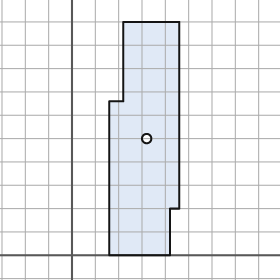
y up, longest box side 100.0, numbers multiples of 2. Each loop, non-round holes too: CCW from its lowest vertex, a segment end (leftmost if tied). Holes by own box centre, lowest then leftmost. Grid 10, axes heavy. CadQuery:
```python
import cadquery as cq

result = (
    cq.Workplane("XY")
    .moveTo(16.0, 0.0)
    .lineTo(42.0, 0.0)
    .lineTo(42.0, 20.0)
    .lineTo(46.0, 20.0)
    .lineTo(46.0, 100.0)
    .lineTo(22.0, 100.0)
    .lineTo(22.0, 66.0)
    .lineTo(16.0, 66.0)
    .close()
    .moveTo(32.0, 50.0)
    .circle(2.0)
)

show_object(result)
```